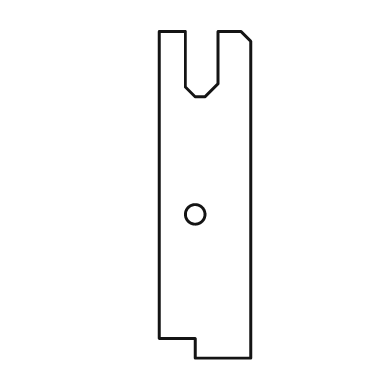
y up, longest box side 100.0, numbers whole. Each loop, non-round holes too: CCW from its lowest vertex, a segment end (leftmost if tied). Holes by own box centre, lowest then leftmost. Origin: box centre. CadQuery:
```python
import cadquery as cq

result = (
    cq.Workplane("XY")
    .moveTo(-3.0, -50.0)
    .lineTo(14.0, -50.0)
    .lineTo(14.0, 47.0)
    .lineTo(11.0, 50.0)
    .lineTo(4.0, 50.0)
    .lineTo(4.0, 34.0)
    .lineTo(0.0, 30.0)
    .lineTo(-3.0, 30.0)
    .lineTo(-6.0, 33.0)
    .lineTo(-6.0, 50.0)
    .lineTo(-14.0, 50.0)
    .lineTo(-14.0, -44.0)
    .lineTo(-3.0, -44.0)
    .close()
    .moveTo(-3.0, -6.0)
    .circle(3.0)
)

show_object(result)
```